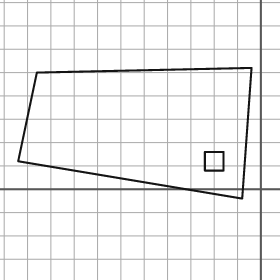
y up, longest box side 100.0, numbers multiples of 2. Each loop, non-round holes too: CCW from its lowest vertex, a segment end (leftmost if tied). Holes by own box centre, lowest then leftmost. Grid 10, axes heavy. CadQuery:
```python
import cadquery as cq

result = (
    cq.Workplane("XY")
    .moveTo(-8.0, -4.0)
    .lineTo(-4.0, 52.0)
    .lineTo(-96.0, 50.0)
    .lineTo(-104.0, 12.0)
    .close()
    .moveTo(-24.0, 8.0)
    .lineTo(-16.0, 8.0)
    .lineTo(-16.0, 16.0)
    .lineTo(-24.0, 16.0)
    .close()
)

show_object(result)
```